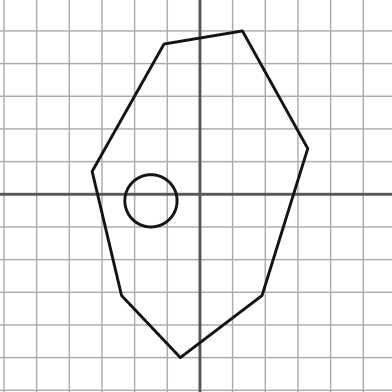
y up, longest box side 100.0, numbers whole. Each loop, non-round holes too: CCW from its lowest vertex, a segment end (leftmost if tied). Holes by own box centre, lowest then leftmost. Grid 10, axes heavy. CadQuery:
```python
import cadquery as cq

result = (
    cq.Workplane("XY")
    .moveTo(-6.0, -50.0)
    .lineTo(19.0, -31.0)
    .lineTo(33.0, 14.0)
    .lineTo(13.0, 50.0)
    .lineTo(-11.0, 46.0)
    .lineTo(-33.0, 7.0)
    .lineTo(-24.0, -31.0)
    .close()
    .moveTo(-15.0, -2.0)
    .circle(8.0)
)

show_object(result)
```